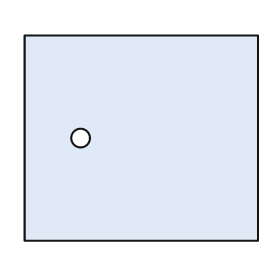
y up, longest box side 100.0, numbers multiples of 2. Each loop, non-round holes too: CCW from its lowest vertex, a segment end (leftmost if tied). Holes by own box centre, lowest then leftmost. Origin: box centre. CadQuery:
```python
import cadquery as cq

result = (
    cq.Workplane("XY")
    .moveTo(-50.0, -44.0)
    .lineTo(50.0, -44.0)
    .lineTo(50.0, 44.0)
    .lineTo(-50.0, 44.0)
    .close()
    .moveTo(-26.0, 0.0)
    .circle(4.0)
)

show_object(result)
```